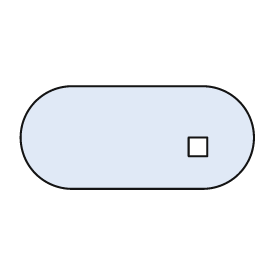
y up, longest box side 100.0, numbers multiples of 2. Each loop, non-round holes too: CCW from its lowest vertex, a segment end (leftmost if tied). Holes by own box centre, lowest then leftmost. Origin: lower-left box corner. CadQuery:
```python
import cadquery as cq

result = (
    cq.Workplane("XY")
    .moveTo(22.0, 0.0)
    .lineTo(78.0, 0.0)
    .threePointArc((100.0, 22.0), (78.0, 44.0))
    .lineTo(22.0, 44.0)
    .threePointArc((0.0, 22.0), (22.0, 0.0))
    .close()
    .moveTo(72.0, 14.0)
    .lineTo(80.0, 14.0)
    .lineTo(80.0, 22.0)
    .lineTo(72.0, 22.0)
    .close()
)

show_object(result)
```